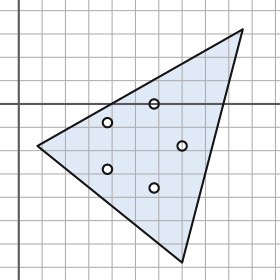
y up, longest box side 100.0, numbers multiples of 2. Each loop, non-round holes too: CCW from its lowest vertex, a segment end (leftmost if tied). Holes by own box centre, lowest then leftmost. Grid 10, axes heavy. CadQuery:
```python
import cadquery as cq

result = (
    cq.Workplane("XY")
    .moveTo(70.0, -68.0)
    .lineTo(96.0, 32.0)
    .lineTo(8.0, -18.0)
    .close()
    .moveTo(58.0, -36.0)
    .circle(2.0)
    .moveTo(38.0, -28.0)
    .circle(2.0)
    .moveTo(70.0, -18.0)
    .circle(2.0)
    .moveTo(38.0, -8.0)
    .circle(2.0)
    .moveTo(58.0, 0.0)
    .circle(2.0)
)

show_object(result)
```